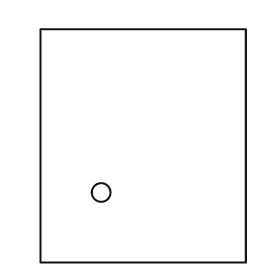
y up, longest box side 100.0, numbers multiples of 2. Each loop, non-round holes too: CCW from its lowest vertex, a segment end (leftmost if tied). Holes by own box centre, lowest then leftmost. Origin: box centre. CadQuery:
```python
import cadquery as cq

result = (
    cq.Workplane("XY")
    .moveTo(-44.0, -50.0)
    .lineTo(44.0, -50.0)
    .lineTo(44.0, 50.0)
    .lineTo(-44.0, 50.0)
    .close()
    .moveTo(-18.0, -20.0)
    .circle(4.0)
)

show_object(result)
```